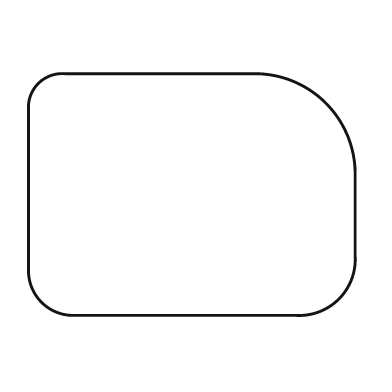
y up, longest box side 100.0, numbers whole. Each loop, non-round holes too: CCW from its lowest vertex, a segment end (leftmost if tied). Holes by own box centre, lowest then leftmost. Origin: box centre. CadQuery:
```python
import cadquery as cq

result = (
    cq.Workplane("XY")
    .moveTo(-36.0, -37.0)
    .lineTo(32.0, -37.0)
    .threePointArc((45.0, -32.0), (50.0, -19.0))
    .lineTo(50.0, 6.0)
    .threePointArc((41.0, 28.0), (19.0, 37.0))
    .lineTo(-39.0, 37.0)
    .threePointArc((-47.0, 34.0), (-50.0, 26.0))
    .lineTo(-50.0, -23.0)
    .threePointArc((-46.0, -33.0), (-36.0, -37.0))
    .close()
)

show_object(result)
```